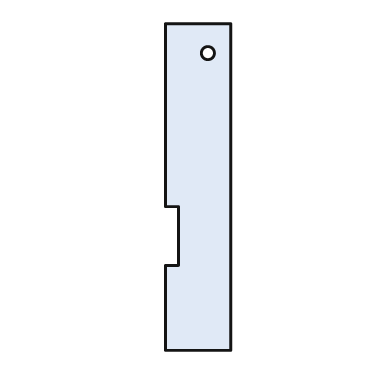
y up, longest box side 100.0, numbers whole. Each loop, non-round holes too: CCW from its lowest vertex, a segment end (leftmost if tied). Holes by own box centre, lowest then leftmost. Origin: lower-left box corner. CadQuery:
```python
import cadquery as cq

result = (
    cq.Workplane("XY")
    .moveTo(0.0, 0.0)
    .lineTo(20.0, 0.0)
    .lineTo(20.0, 100.0)
    .lineTo(0.0, 100.0)
    .lineTo(0.0, 44.0)
    .lineTo(4.0, 44.0)
    .lineTo(4.0, 26.0)
    .lineTo(0.0, 26.0)
    .close()
    .moveTo(13.0, 91.0)
    .circle(2.0)
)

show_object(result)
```